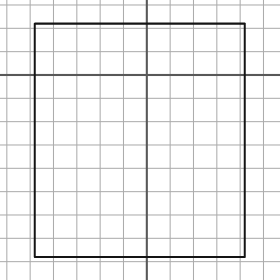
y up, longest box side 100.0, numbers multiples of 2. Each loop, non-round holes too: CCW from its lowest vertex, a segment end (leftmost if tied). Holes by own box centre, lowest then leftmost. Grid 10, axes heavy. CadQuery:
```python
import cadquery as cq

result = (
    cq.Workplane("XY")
    .moveTo(-48.0, -78.0)
    .lineTo(42.0, -78.0)
    .lineTo(42.0, 22.0)
    .lineTo(-48.0, 22.0)
    .close()
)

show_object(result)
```